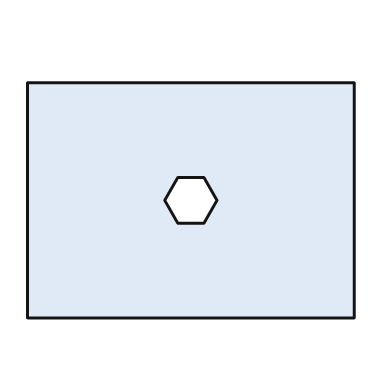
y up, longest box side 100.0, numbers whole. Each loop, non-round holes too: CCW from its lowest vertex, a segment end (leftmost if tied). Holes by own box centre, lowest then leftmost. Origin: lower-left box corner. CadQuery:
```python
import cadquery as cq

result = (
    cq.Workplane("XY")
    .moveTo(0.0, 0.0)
    .lineTo(100.0, 0.0)
    .lineTo(100.0, 72.0)
    .lineTo(0.0, 72.0)
    .close()
    .moveTo(46.0, 29.0)
    .lineTo(54.0, 29.0)
    .lineTo(58.0, 36.0)
    .lineTo(54.0, 43.0)
    .lineTo(46.0, 43.0)
    .lineTo(42.0, 36.0)
    .close()
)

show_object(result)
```